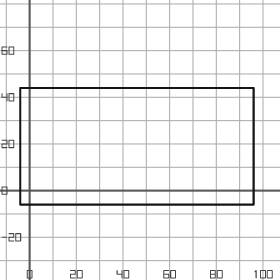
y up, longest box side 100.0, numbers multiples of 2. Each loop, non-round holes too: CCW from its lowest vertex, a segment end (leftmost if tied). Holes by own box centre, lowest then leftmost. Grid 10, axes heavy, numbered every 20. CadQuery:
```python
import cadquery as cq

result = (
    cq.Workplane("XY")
    .moveTo(-4.0, -6.0)
    .lineTo(96.0, -6.0)
    .lineTo(96.0, 44.0)
    .lineTo(-4.0, 44.0)
    .close()
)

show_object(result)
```